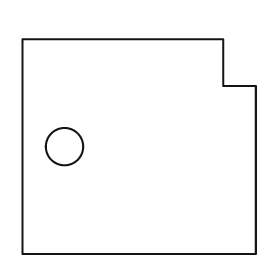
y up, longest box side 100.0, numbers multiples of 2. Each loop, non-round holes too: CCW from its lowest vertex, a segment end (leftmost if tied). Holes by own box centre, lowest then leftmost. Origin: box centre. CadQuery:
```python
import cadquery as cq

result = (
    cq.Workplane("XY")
    .moveTo(-50.0, -46.0)
    .lineTo(50.0, -46.0)
    .lineTo(50.0, 26.0)
    .lineTo(36.0, 26.0)
    .lineTo(36.0, 46.0)
    .lineTo(-50.0, 46.0)
    .close()
    .moveTo(-32.0, 0.0)
    .circle(8.0)
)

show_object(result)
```